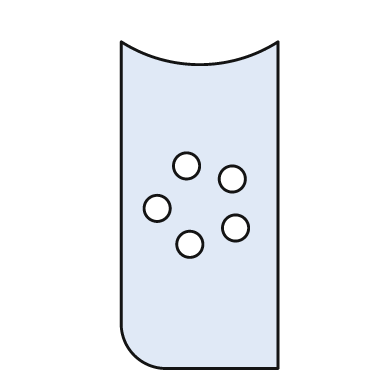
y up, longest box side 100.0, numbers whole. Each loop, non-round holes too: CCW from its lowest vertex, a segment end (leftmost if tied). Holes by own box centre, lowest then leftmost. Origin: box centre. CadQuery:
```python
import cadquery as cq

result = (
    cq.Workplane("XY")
    .moveTo(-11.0, -50.0)
    .lineTo(24.0, -50.0)
    .lineTo(24.0, 50.0)
    .threePointArc((0.0, 43.0), (-24.0, 50.0))
    .lineTo(-24.0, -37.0)
    .threePointArc((-20.0, -46.0), (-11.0, -50.0))
    .close()
    .moveTo(-3.0, -12.0)
    .circle(4.0)
    .moveTo(11.0, -7.0)
    .circle(4.0)
    .moveTo(-13.0, -1.0)
    .circle(4.0)
    .moveTo(10.0, 8.0)
    .circle(4.0)
    .moveTo(-4.0, 12.0)
    .circle(4.0)
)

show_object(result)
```